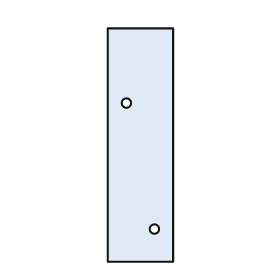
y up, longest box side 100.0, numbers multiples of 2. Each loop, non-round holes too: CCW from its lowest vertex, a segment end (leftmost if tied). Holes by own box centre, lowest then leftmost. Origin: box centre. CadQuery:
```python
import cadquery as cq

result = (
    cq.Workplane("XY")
    .moveTo(-14.0, -50.0)
    .lineTo(14.0, -50.0)
    .lineTo(14.0, 50.0)
    .lineTo(-14.0, 50.0)
    .close()
    .moveTo(6.0, -36.0)
    .circle(2.0)
    .moveTo(-6.0, 18.0)
    .circle(2.0)
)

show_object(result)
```